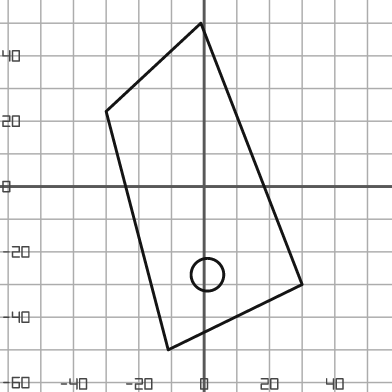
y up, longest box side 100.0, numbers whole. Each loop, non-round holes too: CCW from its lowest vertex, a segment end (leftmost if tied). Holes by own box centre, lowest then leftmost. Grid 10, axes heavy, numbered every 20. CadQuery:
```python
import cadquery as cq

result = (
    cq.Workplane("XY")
    .moveTo(-11.0, -50.0)
    .lineTo(30.0, -30.0)
    .lineTo(-1.0, 50.0)
    .lineTo(-30.0, 23.0)
    .close()
    .moveTo(1.0, -27.0)
    .circle(5.0)
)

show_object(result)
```